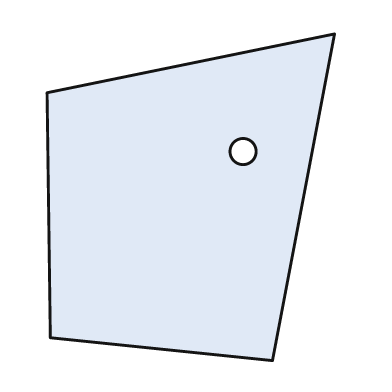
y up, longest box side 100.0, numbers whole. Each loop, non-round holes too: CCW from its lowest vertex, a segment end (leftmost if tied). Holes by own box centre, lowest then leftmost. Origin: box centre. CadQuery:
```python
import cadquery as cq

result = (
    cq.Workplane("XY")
    .moveTo(25.0, -50.0)
    .lineTo(44.0, 50.0)
    .lineTo(-44.0, 32.0)
    .lineTo(-43.0, -43.0)
    .close()
    .moveTo(16.0, 14.0)
    .circle(4.0)
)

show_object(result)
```